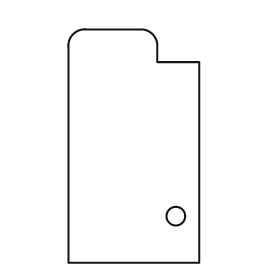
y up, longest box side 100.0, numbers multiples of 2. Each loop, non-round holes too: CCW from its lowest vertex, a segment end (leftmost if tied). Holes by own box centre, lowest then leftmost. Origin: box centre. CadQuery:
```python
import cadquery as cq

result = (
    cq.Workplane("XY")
    .moveTo(-28.0, -50.0)
    .lineTo(28.0, -50.0)
    .lineTo(28.0, 36.0)
    .lineTo(10.0, 36.0)
    .lineTo(10.0, 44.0)
    .threePointArc((8.0, 48.0), (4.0, 50.0))
    .lineTo(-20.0, 50.0)
    .threePointArc((-26.0, 48.0), (-28.0, 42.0))
    .close()
    .moveTo(18.0, -30.0)
    .circle(4.0)
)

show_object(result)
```